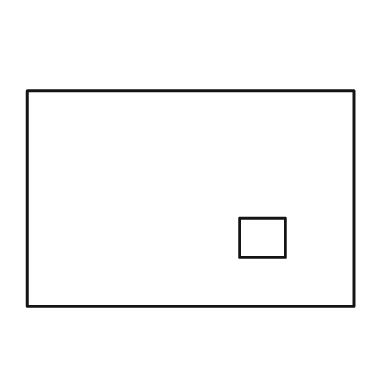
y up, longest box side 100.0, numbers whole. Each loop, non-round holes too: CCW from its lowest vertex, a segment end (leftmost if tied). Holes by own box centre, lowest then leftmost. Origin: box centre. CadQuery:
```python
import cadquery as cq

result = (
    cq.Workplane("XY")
    .moveTo(-50.0, -33.0)
    .lineTo(50.0, -33.0)
    .lineTo(50.0, 33.0)
    .lineTo(-50.0, 33.0)
    .close()
    .moveTo(15.0, -18.0)
    .lineTo(29.0, -18.0)
    .lineTo(29.0, -6.0)
    .lineTo(15.0, -6.0)
    .close()
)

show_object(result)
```